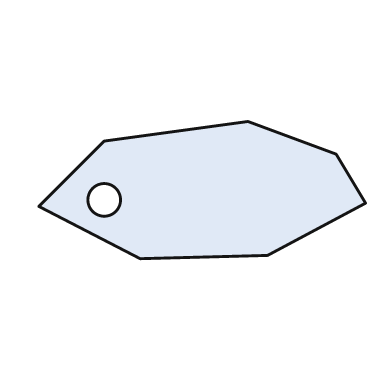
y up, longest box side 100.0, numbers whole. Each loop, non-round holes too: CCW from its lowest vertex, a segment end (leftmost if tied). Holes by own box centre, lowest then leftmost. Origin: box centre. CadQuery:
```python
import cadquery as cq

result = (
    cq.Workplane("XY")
    .moveTo(-19.0, -21.0)
    .lineTo(20.0, -20.0)
    .lineTo(50.0, -4.0)
    .lineTo(41.0, 11.0)
    .lineTo(14.0, 21.0)
    .lineTo(-30.0, 15.0)
    .lineTo(-50.0, -5.0)
    .close()
    .moveTo(-30.0, -3.0)
    .circle(5.0)
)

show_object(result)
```